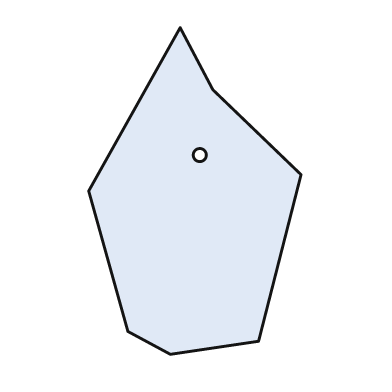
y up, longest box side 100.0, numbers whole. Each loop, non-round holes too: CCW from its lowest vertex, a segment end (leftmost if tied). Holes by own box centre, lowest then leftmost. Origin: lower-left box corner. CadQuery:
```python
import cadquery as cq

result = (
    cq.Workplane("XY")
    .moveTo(25.0, 0.0)
    .lineTo(52.0, 4.0)
    .lineTo(65.0, 55.0)
    .lineTo(38.0, 81.0)
    .lineTo(28.0, 100.0)
    .lineTo(0.0, 50.0)
    .lineTo(12.0, 7.0)
    .close()
    .moveTo(34.0, 61.0)
    .circle(2.0)
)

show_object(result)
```